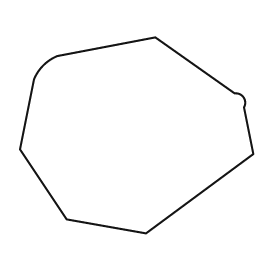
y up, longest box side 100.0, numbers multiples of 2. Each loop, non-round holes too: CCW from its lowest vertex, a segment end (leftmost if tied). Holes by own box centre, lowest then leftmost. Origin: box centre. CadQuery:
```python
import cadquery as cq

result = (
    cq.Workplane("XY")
    .moveTo(4.0, -42.0)
    .lineTo(50.0, -8.0)
    .lineTo(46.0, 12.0)
    .threePointArc((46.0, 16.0), (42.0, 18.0))
    .lineTo(8.0, 42.0)
    .lineTo(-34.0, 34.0)
    .threePointArc((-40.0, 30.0), (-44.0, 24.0))
    .lineTo(-50.0, -6.0)
    .lineTo(-30.0, -36.0)
    .close()
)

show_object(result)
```